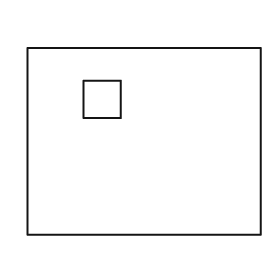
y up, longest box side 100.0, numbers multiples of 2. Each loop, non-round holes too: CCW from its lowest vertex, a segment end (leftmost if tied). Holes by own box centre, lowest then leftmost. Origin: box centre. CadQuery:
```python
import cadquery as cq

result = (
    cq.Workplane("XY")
    .moveTo(-50.0, -40.0)
    .lineTo(50.0, -40.0)
    .lineTo(50.0, 40.0)
    .lineTo(-50.0, 40.0)
    .close()
    .moveTo(-26.0, 10.0)
    .lineTo(-10.0, 10.0)
    .lineTo(-10.0, 26.0)
    .lineTo(-26.0, 26.0)
    .close()
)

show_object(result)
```